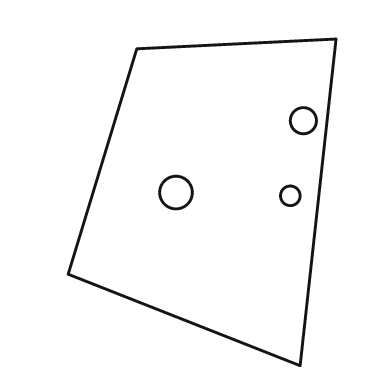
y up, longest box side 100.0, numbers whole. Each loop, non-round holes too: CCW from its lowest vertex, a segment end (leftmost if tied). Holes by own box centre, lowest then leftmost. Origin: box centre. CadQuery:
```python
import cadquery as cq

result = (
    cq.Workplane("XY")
    .moveTo(30.0, -50.0)
    .lineTo(41.0, 50.0)
    .lineTo(-20.0, 47.0)
    .lineTo(-41.0, -22.0)
    .close()
    .moveTo(27.0, 2.0)
    .circle(3.0)
    .moveTo(-8.0, 3.0)
    .circle(5.0)
    .moveTo(31.0, 25.0)
    .circle(4.0)
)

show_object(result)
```